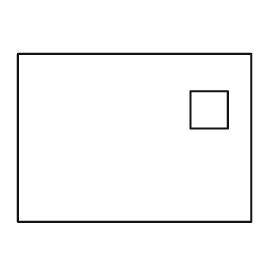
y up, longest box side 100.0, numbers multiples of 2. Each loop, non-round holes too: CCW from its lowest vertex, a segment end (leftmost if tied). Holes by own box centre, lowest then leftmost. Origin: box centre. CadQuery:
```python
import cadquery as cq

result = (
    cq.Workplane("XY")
    .moveTo(-50.0, -36.0)
    .lineTo(50.0, -36.0)
    .lineTo(50.0, 36.0)
    .lineTo(-50.0, 36.0)
    .close()
    .moveTo(24.0, 4.0)
    .lineTo(40.0, 4.0)
    .lineTo(40.0, 20.0)
    .lineTo(24.0, 20.0)
    .close()
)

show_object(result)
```